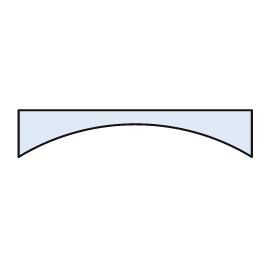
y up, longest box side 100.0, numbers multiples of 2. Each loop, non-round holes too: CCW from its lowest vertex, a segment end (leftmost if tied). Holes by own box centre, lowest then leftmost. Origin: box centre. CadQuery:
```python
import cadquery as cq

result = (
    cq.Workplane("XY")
    .moveTo(-50.0, -10.0)
    .threePointArc((0.0, 4.0), (50.0, -10.0))
    .lineTo(50.0, 10.0)
    .lineTo(-50.0, 10.0)
    .close()
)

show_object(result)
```